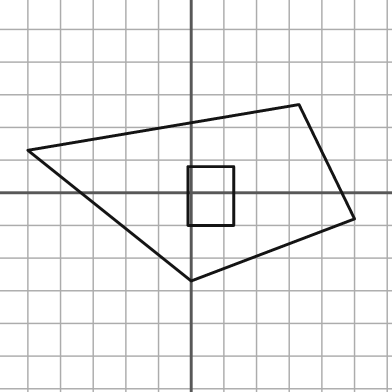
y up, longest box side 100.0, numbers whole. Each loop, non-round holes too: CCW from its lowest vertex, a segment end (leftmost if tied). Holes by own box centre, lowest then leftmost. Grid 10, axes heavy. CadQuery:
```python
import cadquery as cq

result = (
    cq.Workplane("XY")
    .moveTo(0.0, -27.0)
    .lineTo(50.0, -8.0)
    .lineTo(33.0, 27.0)
    .lineTo(-50.0, 13.0)
    .close()
    .moveTo(-1.0, -10.0)
    .lineTo(13.0, -10.0)
    .lineTo(13.0, 8.0)
    .lineTo(-1.0, 8.0)
    .close()
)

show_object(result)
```